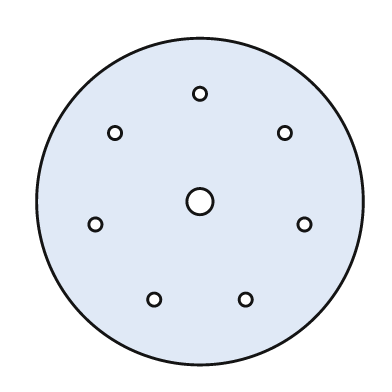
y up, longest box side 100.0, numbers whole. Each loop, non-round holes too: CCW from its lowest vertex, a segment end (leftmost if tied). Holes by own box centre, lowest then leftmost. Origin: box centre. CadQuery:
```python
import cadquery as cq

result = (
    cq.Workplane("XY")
    .moveTo(0.0, 0.0)
    .circle(50.0)
    .moveTo(-14.0, -30.0)
    .circle(2.0)
    .moveTo(14.0, -30.0)
    .circle(2.0)
    .moveTo(-32.0, -7.0)
    .circle(2.0)
    .moveTo(32.0, -7.0)
    .circle(2.0)
    .moveTo(0.0, 0.0)
    .circle(4.0)
    .moveTo(-26.0, 21.0)
    .circle(2.0)
    .moveTo(26.0, 21.0)
    .circle(2.0)
    .moveTo(0.0, 33.0)
    .circle(2.0)
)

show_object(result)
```